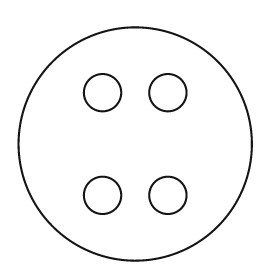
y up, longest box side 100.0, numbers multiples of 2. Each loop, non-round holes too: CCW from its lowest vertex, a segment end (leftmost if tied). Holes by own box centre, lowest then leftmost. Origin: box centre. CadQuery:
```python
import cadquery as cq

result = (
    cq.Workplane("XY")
    .moveTo(0.0, 0.0)
    .circle(50.0)
    .moveTo(-14.0, -22.0)
    .circle(8.0)
    .moveTo(14.0, -22.0)
    .circle(8.0)
    .moveTo(-14.0, 22.0)
    .circle(8.0)
    .moveTo(14.0, 22.0)
    .circle(8.0)
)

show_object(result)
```